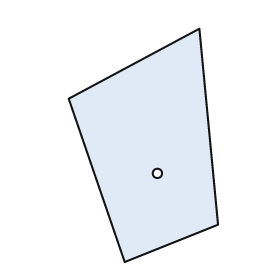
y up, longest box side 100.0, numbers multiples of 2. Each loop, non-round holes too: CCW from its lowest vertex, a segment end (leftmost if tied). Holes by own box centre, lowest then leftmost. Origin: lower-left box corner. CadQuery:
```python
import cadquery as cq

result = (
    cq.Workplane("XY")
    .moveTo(24.0, 0.0)
    .lineTo(64.0, 16.0)
    .lineTo(56.0, 100.0)
    .lineTo(0.0, 70.0)
    .close()
    .moveTo(38.0, 38.0)
    .circle(2.0)
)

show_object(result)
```